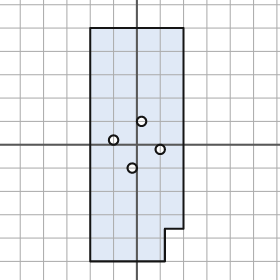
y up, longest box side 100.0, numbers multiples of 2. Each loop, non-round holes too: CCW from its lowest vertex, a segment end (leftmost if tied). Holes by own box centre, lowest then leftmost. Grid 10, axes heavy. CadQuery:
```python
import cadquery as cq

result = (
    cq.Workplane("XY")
    .moveTo(-20.0, -50.0)
    .lineTo(12.0, -50.0)
    .lineTo(12.0, -36.0)
    .lineTo(20.0, -36.0)
    .lineTo(20.0, 50.0)
    .lineTo(-20.0, 50.0)
    .close()
    .moveTo(-2.0, -10.0)
    .circle(2.0)
    .moveTo(10.0, -2.0)
    .circle(2.0)
    .moveTo(-10.0, 2.0)
    .circle(2.0)
    .moveTo(2.0, 10.0)
    .circle(2.0)
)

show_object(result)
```